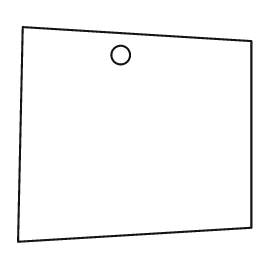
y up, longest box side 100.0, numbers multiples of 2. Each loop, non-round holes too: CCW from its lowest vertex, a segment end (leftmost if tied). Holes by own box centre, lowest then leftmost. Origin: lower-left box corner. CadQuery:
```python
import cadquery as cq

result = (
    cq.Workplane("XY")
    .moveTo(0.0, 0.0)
    .lineTo(100.0, 6.0)
    .lineTo(100.0, 86.0)
    .lineTo(2.0, 92.0)
    .close()
    .moveTo(44.0, 80.0)
    .circle(4.0)
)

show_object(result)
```